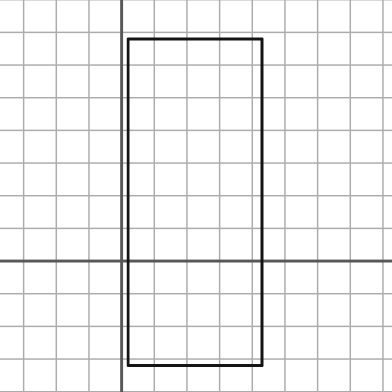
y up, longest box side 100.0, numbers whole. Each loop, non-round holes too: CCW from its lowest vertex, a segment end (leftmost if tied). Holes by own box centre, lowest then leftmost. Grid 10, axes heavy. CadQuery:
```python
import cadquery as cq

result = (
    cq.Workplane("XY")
    .moveTo(2.0, -32.0)
    .lineTo(43.0, -32.0)
    .lineTo(43.0, 68.0)
    .lineTo(2.0, 68.0)
    .close()
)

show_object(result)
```